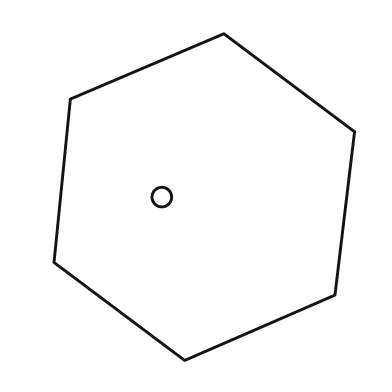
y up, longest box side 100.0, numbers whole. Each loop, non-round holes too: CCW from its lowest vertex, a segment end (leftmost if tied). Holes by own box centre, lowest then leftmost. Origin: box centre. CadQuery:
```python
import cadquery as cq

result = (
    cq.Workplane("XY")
    .moveTo(-6.0, -50.0)
    .lineTo(40.0, -30.0)
    .lineTo(46.0, 20.0)
    .lineTo(6.0, 50.0)
    .lineTo(-41.0, 30.0)
    .lineTo(-46.0, -20.0)
    .close()
    .moveTo(-13.0, 0.0)
    .circle(3.0)
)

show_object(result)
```